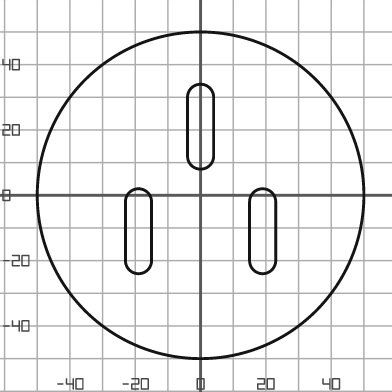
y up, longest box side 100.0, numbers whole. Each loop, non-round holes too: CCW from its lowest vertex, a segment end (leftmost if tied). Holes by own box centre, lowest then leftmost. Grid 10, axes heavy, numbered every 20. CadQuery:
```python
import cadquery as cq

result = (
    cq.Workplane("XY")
    .moveTo(0.0, 0.0)
    .circle(50.0)
    .moveTo(-23.0, -20.0)
    .threePointArc((-19.0, -24.0), (-15.0, -20.0))
    .lineTo(-15.0, -2.0)
    .threePointArc((-19.0, 2.0), (-23.0, -2.0))
    .close()
    .moveTo(15.0, -20.0)
    .threePointArc((19.0, -24.0), (23.0, -20.0))
    .lineTo(23.0, -2.0)
    .threePointArc((19.0, 2.0), (15.0, -2.0))
    .close()
    .moveTo(-4.0, 12.0)
    .threePointArc((0.0, 8.0), (4.0, 12.0))
    .lineTo(4.0, 30.0)
    .threePointArc((0.0, 34.0), (-4.0, 30.0))
    .close()
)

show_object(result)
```